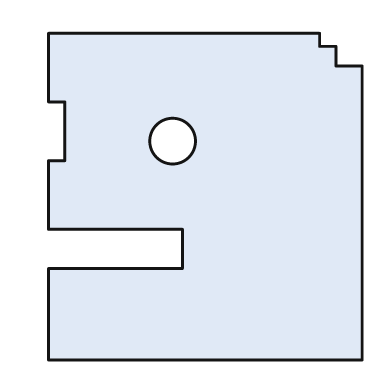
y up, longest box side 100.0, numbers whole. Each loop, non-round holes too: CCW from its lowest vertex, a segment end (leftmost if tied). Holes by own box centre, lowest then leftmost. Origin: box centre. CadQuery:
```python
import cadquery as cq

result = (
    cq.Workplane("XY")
    .moveTo(-48.0, -50.0)
    .lineTo(48.0, -50.0)
    .lineTo(48.0, 40.0)
    .lineTo(40.0, 40.0)
    .lineTo(40.0, 46.0)
    .lineTo(35.0, 46.0)
    .lineTo(35.0, 50.0)
    .lineTo(-48.0, 50.0)
    .lineTo(-48.0, 29.0)
    .lineTo(-43.0, 29.0)
    .lineTo(-43.0, 11.0)
    .lineTo(-48.0, 11.0)
    .lineTo(-48.0, -10.0)
    .lineTo(-7.0, -10.0)
    .lineTo(-7.0, -22.0)
    .lineTo(-48.0, -22.0)
    .close()
    .moveTo(-10.0, 17.0)
    .circle(7.0)
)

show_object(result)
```